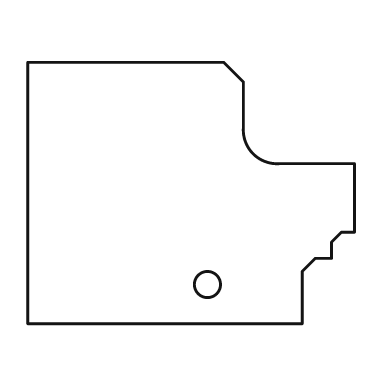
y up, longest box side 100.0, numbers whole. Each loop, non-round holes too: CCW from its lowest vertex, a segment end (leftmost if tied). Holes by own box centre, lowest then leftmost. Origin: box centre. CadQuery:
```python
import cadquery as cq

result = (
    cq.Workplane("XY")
    .moveTo(-50.0, -40.0)
    .lineTo(34.0, -40.0)
    .lineTo(34.0, -24.0)
    .lineTo(38.0, -20.0)
    .lineTo(43.0, -20.0)
    .lineTo(43.0, -15.0)
    .lineTo(46.0, -12.0)
    .lineTo(50.0, -12.0)
    .lineTo(50.0, 9.0)
    .lineTo(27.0, 9.0)
    .threePointArc((19.0, 12.0), (16.0, 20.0))
    .lineTo(16.0, 34.0)
    .lineTo(10.0, 40.0)
    .lineTo(-50.0, 40.0)
    .close()
    .moveTo(5.0, -28.0)
    .circle(4.0)
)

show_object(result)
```